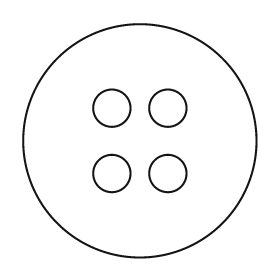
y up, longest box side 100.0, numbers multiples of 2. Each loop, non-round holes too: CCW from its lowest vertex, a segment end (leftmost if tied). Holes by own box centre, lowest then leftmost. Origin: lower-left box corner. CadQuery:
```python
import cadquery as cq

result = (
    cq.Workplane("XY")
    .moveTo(50.0, 50.0)
    .circle(50.0)
    .moveTo(38.0, 36.0)
    .circle(8.0)
    .moveTo(62.0, 36.0)
    .circle(8.0)
    .moveTo(38.0, 64.0)
    .circle(8.0)
    .moveTo(62.0, 64.0)
    .circle(8.0)
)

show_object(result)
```